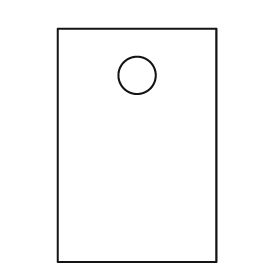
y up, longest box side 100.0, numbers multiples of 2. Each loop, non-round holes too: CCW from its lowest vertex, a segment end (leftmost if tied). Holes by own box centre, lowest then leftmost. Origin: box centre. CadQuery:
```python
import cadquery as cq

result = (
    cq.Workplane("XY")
    .moveTo(-34.0, -50.0)
    .lineTo(34.0, -50.0)
    .lineTo(34.0, 50.0)
    .lineTo(-34.0, 50.0)
    .close()
    .moveTo(0.0, 30.0)
    .circle(8.0)
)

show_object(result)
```